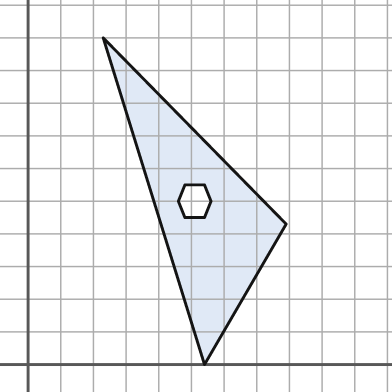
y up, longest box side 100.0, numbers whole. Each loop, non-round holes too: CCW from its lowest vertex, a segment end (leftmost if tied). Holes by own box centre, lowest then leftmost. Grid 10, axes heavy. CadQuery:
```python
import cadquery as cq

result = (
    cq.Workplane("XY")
    .moveTo(54.0, 0.0)
    .lineTo(79.0, 43.0)
    .lineTo(23.0, 100.0)
    .close()
    .moveTo(48.0, 45.0)
    .lineTo(54.0, 45.0)
    .lineTo(56.0, 50.0)
    .lineTo(54.0, 55.0)
    .lineTo(48.0, 55.0)
    .lineTo(46.0, 50.0)
    .close()
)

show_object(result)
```